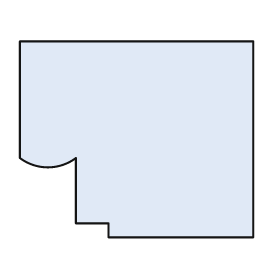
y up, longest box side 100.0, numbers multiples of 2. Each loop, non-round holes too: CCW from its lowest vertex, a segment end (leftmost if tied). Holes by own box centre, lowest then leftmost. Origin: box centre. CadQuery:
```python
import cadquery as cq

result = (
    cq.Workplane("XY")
    .moveTo(-12.0, -42.0)
    .lineTo(50.0, -42.0)
    .lineTo(50.0, 42.0)
    .lineTo(-50.0, 42.0)
    .lineTo(-50.0, -8.0)
    .threePointArc((-38.0, -12.0), (-26.0, -8.0))
    .lineTo(-26.0, -36.0)
    .lineTo(-12.0, -36.0)
    .close()
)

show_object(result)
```